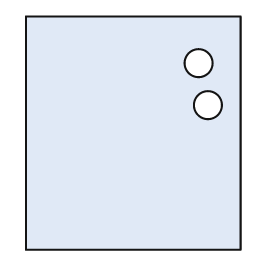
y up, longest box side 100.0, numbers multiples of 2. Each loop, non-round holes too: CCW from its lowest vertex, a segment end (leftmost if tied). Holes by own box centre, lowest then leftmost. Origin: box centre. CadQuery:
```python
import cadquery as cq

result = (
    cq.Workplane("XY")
    .moveTo(-46.0, -50.0)
    .lineTo(46.0, -50.0)
    .lineTo(46.0, 50.0)
    .lineTo(-46.0, 50.0)
    .close()
    .moveTo(32.0, 12.0)
    .circle(6.0)
    .moveTo(28.0, 30.0)
    .circle(6.0)
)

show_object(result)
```